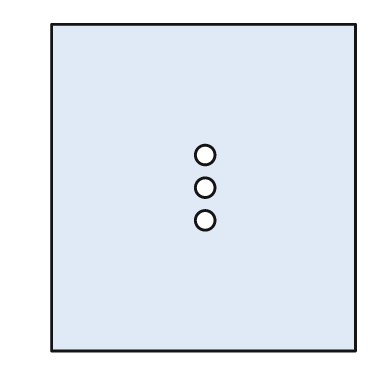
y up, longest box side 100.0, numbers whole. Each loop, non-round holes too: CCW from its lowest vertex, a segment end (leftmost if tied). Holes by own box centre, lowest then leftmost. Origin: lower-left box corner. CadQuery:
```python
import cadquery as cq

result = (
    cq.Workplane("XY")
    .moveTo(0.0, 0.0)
    .lineTo(93.0, 0.0)
    .lineTo(93.0, 100.0)
    .lineTo(0.0, 100.0)
    .close()
    .moveTo(47.0, 40.0)
    .circle(3.0)
    .moveTo(47.0, 50.0)
    .circle(3.0)
    .moveTo(47.0, 60.0)
    .circle(3.0)
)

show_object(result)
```